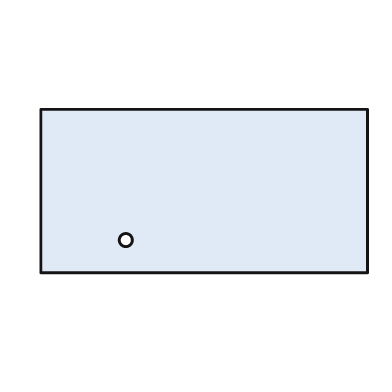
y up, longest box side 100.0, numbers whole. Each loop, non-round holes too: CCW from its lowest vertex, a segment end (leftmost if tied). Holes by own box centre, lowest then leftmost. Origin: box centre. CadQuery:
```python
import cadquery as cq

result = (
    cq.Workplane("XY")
    .moveTo(-50.0, -25.0)
    .lineTo(50.0, -25.0)
    .lineTo(50.0, 25.0)
    .lineTo(-50.0, 25.0)
    .close()
    .moveTo(-24.0, -15.0)
    .circle(2.0)
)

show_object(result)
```